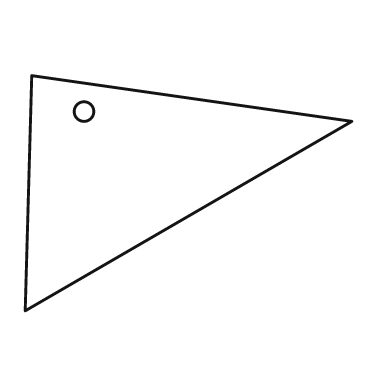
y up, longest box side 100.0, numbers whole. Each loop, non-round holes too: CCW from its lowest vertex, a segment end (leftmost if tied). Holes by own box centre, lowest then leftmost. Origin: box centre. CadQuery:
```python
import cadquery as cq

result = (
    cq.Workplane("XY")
    .moveTo(-50.0, -36.0)
    .lineTo(50.0, 22.0)
    .lineTo(-48.0, 36.0)
    .close()
    .moveTo(-32.0, 25.0)
    .circle(3.0)
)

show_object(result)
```